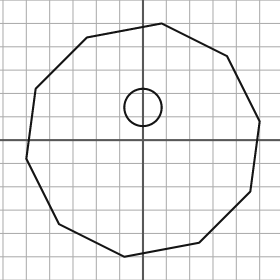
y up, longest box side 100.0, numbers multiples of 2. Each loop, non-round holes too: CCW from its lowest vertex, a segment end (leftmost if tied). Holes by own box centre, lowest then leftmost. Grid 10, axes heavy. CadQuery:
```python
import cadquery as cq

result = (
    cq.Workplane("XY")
    .moveTo(-8.0, -50.0)
    .lineTo(24.0, -44.0)
    .lineTo(46.0, -22.0)
    .lineTo(50.0, 8.0)
    .lineTo(36.0, 36.0)
    .lineTo(8.0, 50.0)
    .lineTo(-24.0, 44.0)
    .lineTo(-46.0, 22.0)
    .lineTo(-50.0, -8.0)
    .lineTo(-36.0, -36.0)
    .close()
    .moveTo(0.0, 14.0)
    .circle(8.0)
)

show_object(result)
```